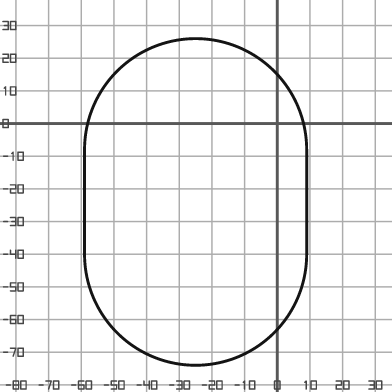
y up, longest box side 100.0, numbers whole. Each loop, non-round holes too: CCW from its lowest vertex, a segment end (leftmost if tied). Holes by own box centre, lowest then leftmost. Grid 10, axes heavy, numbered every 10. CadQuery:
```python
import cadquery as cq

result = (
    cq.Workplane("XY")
    .moveTo(-59.0, -40.0)
    .threePointArc((-25.0, -74.0), (9.0, -40.0))
    .lineTo(9.0, -8.0)
    .threePointArc((-25.0, 26.0), (-59.0, -8.0))
    .close()
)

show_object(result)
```